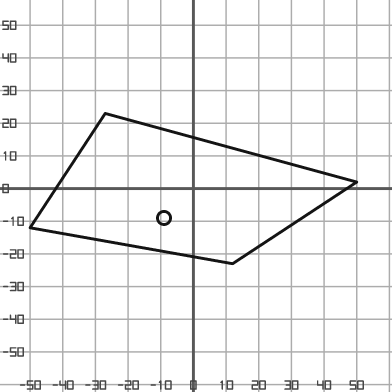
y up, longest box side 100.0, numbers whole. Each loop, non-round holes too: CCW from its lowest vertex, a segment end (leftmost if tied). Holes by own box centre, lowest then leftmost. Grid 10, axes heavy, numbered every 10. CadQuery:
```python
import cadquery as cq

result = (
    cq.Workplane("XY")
    .moveTo(12.0, -23.0)
    .lineTo(50.0, 2.0)
    .lineTo(-27.0, 23.0)
    .lineTo(-50.0, -12.0)
    .close()
    .moveTo(-9.0, -9.0)
    .circle(2.0)
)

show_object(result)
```